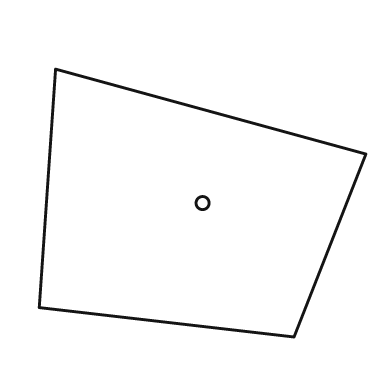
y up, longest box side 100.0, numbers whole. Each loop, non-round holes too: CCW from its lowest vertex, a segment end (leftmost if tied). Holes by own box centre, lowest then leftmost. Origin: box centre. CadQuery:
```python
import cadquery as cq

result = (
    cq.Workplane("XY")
    .moveTo(28.0, -41.0)
    .lineTo(50.0, 15.0)
    .lineTo(-45.0, 41.0)
    .lineTo(-50.0, -32.0)
    .close()
    .moveTo(0.0, 0.0)
    .circle(2.0)
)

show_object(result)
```